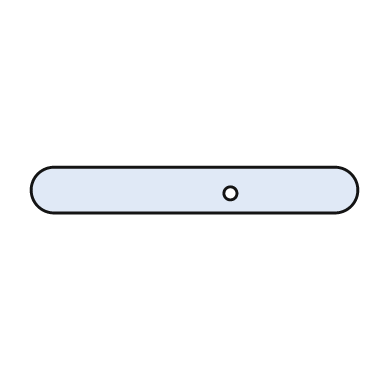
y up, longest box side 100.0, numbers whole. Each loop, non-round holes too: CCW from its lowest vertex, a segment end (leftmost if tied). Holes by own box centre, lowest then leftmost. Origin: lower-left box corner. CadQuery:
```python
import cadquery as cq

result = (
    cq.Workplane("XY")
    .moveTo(7.0, 0.0)
    .lineTo(93.0, 0.0)
    .threePointArc((100.0, 7.0), (93.0, 14.0))
    .lineTo(7.0, 14.0)
    .threePointArc((0.0, 7.0), (7.0, 0.0))
    .close()
    .moveTo(61.0, 6.0)
    .circle(2.0)
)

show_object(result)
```